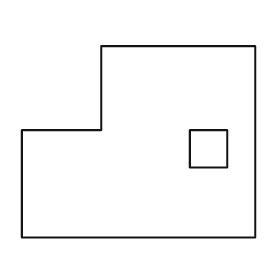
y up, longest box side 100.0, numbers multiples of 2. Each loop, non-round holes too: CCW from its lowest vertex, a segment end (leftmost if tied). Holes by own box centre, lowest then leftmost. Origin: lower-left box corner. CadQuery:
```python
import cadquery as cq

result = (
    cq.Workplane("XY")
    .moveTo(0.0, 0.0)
    .lineTo(100.0, 0.0)
    .lineTo(100.0, 82.0)
    .lineTo(34.0, 82.0)
    .lineTo(34.0, 46.0)
    .lineTo(0.0, 46.0)
    .close()
    .moveTo(72.0, 30.0)
    .lineTo(88.0, 30.0)
    .lineTo(88.0, 46.0)
    .lineTo(72.0, 46.0)
    .close()
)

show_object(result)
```